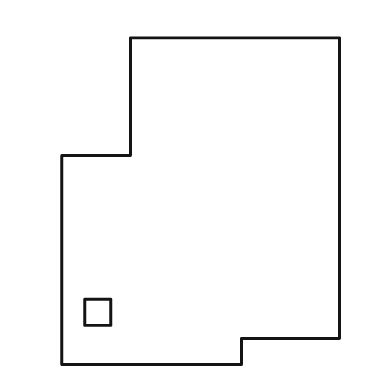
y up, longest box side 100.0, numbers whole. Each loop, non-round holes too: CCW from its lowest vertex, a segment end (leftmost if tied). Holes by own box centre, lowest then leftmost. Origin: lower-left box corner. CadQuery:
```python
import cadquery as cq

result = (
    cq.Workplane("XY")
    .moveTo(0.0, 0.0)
    .lineTo(55.0, 0.0)
    .lineTo(55.0, 8.0)
    .lineTo(85.0, 8.0)
    .lineTo(85.0, 100.0)
    .lineTo(21.0, 100.0)
    .lineTo(21.0, 64.0)
    .lineTo(0.0, 64.0)
    .close()
    .moveTo(7.0, 12.0)
    .lineTo(15.0, 12.0)
    .lineTo(15.0, 20.0)
    .lineTo(7.0, 20.0)
    .close()
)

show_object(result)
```